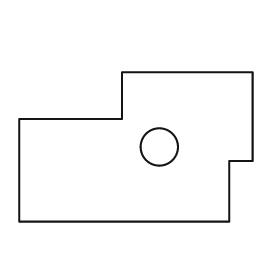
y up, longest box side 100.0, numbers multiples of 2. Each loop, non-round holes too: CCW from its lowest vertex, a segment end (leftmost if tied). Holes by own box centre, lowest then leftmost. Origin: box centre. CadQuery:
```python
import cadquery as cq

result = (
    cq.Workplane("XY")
    .moveTo(-50.0, -32.0)
    .lineTo(40.0, -32.0)
    .lineTo(40.0, -6.0)
    .lineTo(50.0, -6.0)
    .lineTo(50.0, 32.0)
    .lineTo(-6.0, 32.0)
    .lineTo(-6.0, 12.0)
    .lineTo(-50.0, 12.0)
    .close()
    .moveTo(10.0, 0.0)
    .circle(8.0)
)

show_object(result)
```